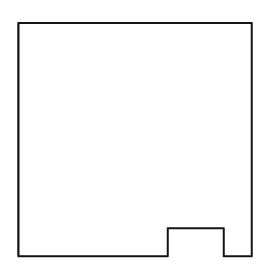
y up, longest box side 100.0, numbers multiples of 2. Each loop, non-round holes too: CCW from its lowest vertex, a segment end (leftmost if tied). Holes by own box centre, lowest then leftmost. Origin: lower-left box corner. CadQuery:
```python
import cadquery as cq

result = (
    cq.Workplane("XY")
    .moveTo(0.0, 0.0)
    .lineTo(64.0, 0.0)
    .lineTo(64.0, 12.0)
    .lineTo(88.0, 12.0)
    .lineTo(88.0, 0.0)
    .lineTo(100.0, 0.0)
    .lineTo(100.0, 100.0)
    .lineTo(0.0, 100.0)
    .close()
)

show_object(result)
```